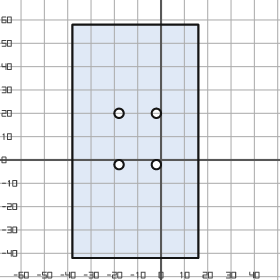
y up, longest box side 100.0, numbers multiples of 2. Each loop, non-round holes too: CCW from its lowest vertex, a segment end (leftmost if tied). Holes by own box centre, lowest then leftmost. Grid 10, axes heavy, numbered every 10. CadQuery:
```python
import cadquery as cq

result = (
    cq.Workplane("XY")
    .moveTo(-38.0, -42.0)
    .lineTo(16.0, -42.0)
    .lineTo(16.0, 58.0)
    .lineTo(-38.0, 58.0)
    .close()
    .moveTo(-18.0, -2.0)
    .circle(2.0)
    .moveTo(-2.0, -2.0)
    .circle(2.0)
    .moveTo(-18.0, 20.0)
    .circle(2.0)
    .moveTo(-2.0, 20.0)
    .circle(2.0)
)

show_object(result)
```